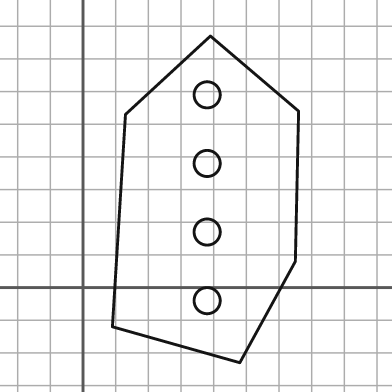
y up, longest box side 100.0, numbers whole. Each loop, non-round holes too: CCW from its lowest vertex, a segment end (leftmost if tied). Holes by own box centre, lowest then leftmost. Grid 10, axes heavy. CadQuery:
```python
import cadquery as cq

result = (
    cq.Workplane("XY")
    .moveTo(48.0, -23.0)
    .lineTo(65.0, 8.0)
    .lineTo(66.0, 54.0)
    .lineTo(39.0, 77.0)
    .lineTo(13.0, 53.0)
    .lineTo(9.0, -12.0)
    .close()
    .moveTo(38.0, -4.0)
    .circle(4.0)
    .moveTo(38.0, 17.0)
    .circle(4.0)
    .moveTo(38.0, 38.0)
    .circle(4.0)
    .moveTo(38.0, 59.0)
    .circle(4.0)
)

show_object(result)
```